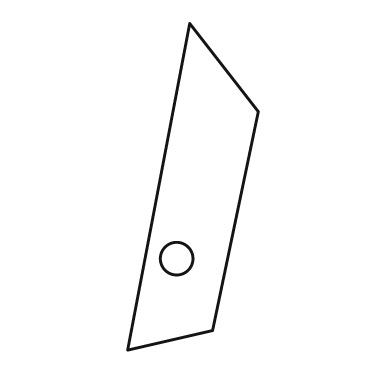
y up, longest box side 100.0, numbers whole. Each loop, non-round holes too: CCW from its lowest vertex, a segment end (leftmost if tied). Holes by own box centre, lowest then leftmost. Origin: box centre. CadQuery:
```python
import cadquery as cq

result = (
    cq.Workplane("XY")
    .moveTo(-20.0, -50.0)
    .lineTo(6.0, -44.0)
    .lineTo(20.0, 23.0)
    .lineTo(-1.0, 50.0)
    .close()
    .moveTo(-5.0, -22.0)
    .circle(5.0)
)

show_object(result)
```